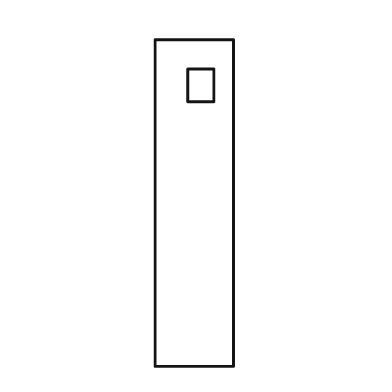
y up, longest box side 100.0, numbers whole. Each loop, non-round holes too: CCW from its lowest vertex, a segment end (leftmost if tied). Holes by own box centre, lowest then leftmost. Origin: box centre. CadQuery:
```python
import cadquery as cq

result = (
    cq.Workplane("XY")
    .moveTo(-12.0, -50.0)
    .lineTo(12.0, -50.0)
    .lineTo(12.0, 50.0)
    .lineTo(-12.0, 50.0)
    .close()
    .moveTo(-2.0, 31.0)
    .lineTo(6.0, 31.0)
    .lineTo(6.0, 41.0)
    .lineTo(-2.0, 41.0)
    .close()
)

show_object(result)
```